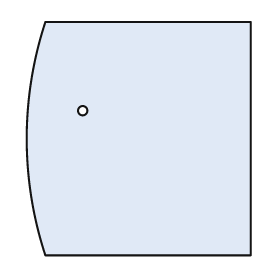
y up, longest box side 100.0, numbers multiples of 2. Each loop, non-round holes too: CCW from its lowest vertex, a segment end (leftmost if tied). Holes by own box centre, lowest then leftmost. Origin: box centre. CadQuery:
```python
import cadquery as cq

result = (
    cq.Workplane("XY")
    .moveTo(-40.0, -50.0)
    .lineTo(48.0, -50.0)
    .lineTo(48.0, 50.0)
    .lineTo(-40.0, 50.0)
    .threePointArc((-48.0, 0.0), (-40.0, -50.0))
    .close()
    .moveTo(-24.0, 12.0)
    .circle(2.0)
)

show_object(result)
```